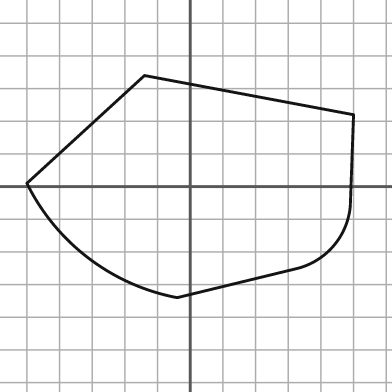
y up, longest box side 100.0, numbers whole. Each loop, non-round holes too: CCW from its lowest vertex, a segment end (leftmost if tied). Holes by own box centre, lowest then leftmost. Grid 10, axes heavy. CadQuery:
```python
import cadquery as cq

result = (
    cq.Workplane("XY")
    .moveTo(-4.0, -34.0)
    .lineTo(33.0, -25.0)
    .threePointArc((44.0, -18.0), (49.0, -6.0))
    .lineTo(50.0, 22.0)
    .lineTo(-14.0, 34.0)
    .lineTo(-50.0, 1.0)
    .threePointArc((-31.0, -22.0), (-4.0, -34.0))
    .close()
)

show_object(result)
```